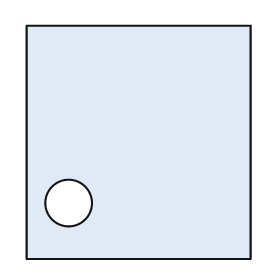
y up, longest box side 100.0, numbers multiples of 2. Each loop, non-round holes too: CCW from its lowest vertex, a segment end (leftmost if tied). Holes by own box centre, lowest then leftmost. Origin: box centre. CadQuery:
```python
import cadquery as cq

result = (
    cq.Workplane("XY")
    .moveTo(-48.0, -50.0)
    .lineTo(48.0, -50.0)
    .lineTo(48.0, 50.0)
    .lineTo(-48.0, 50.0)
    .close()
    .moveTo(-30.0, -26.0)
    .circle(10.0)
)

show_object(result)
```